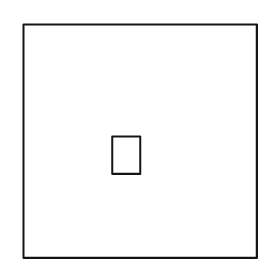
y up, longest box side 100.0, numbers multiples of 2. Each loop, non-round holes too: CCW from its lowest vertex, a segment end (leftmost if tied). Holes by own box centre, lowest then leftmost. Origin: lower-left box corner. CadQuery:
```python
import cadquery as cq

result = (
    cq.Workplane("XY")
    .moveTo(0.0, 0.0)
    .lineTo(100.0, 0.0)
    .lineTo(100.0, 100.0)
    .lineTo(0.0, 100.0)
    .close()
    .moveTo(38.0, 36.0)
    .lineTo(50.0, 36.0)
    .lineTo(50.0, 52.0)
    .lineTo(38.0, 52.0)
    .close()
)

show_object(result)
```